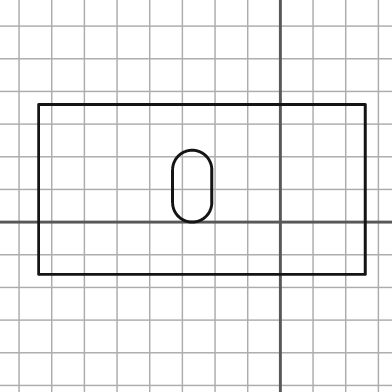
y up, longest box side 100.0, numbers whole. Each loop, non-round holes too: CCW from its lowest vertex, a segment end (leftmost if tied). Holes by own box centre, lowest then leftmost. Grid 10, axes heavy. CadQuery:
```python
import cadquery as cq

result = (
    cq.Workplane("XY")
    .moveTo(-74.0, -16.0)
    .lineTo(26.0, -16.0)
    .lineTo(26.0, 36.0)
    .lineTo(-74.0, 36.0)
    .close()
    .moveTo(-33.0, 6.0)
    .threePointArc((-27.0, 0.0), (-21.0, 6.0))
    .lineTo(-21.0, 16.0)
    .threePointArc((-27.0, 22.0), (-33.0, 16.0))
    .close()
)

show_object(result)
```